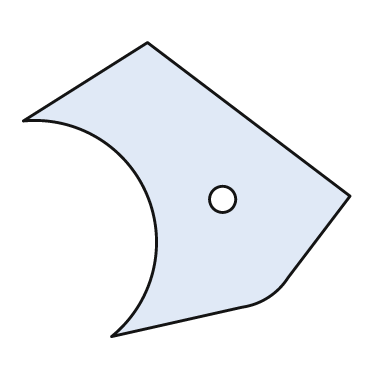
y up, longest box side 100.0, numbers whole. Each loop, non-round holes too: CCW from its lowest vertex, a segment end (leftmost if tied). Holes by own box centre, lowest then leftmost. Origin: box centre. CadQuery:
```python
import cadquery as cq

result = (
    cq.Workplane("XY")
    .moveTo(-23.0, -45.0)
    .lineTo(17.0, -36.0)
    .threePointArc((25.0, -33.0), (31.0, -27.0))
    .lineTo(50.0, -2.0)
    .lineTo(-12.0, 45.0)
    .lineTo(-50.0, 21.0)
    .threePointArc((-12.0, -2.0), (-23.0, -45.0))
    .close()
    .moveTo(11.0, -3.0)
    .circle(4.0)
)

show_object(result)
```